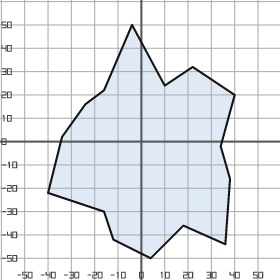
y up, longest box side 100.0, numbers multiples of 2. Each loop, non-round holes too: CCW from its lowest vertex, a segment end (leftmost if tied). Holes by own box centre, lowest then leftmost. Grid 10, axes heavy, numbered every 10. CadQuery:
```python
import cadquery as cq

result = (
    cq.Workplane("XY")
    .moveTo(4.0, -50.0)
    .lineTo(18.0, -36.0)
    .lineTo(36.0, -44.0)
    .lineTo(38.0, -16.0)
    .lineTo(34.0, -2.0)
    .lineTo(40.0, 20.0)
    .lineTo(22.0, 32.0)
    .lineTo(10.0, 24.0)
    .lineTo(-4.0, 50.0)
    .lineTo(-16.0, 22.0)
    .lineTo(-24.0, 16.0)
    .lineTo(-34.0, 2.0)
    .lineTo(-40.0, -22.0)
    .lineTo(-16.0, -30.0)
    .lineTo(-12.0, -42.0)
    .close()
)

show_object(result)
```